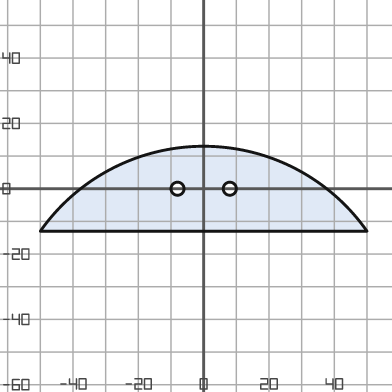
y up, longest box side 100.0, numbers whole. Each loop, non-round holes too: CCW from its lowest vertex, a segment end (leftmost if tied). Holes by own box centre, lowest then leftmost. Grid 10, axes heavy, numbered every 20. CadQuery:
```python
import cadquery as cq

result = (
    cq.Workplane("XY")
    .moveTo(-50.0, -13.0)
    .lineTo(50.0, -13.0)
    .threePointArc((0.0, 13.0), (-50.0, -13.0))
    .close()
    .moveTo(-8.0, 0.0)
    .circle(2.0)
    .moveTo(8.0, 0.0)
    .circle(2.0)
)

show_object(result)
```